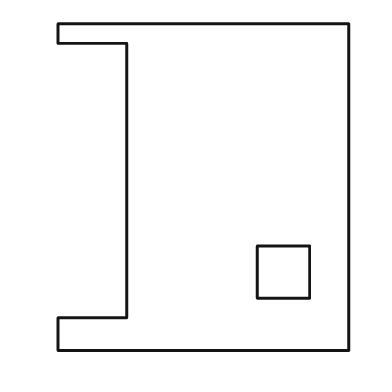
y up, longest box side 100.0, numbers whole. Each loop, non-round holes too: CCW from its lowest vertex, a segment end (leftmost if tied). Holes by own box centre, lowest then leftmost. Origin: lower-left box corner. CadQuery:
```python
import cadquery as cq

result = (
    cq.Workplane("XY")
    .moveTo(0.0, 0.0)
    .lineTo(89.0, 0.0)
    .lineTo(89.0, 100.0)
    .lineTo(0.0, 100.0)
    .lineTo(0.0, 94.0)
    .lineTo(21.0, 94.0)
    .lineTo(21.0, 10.0)
    .lineTo(0.0, 10.0)
    .close()
    .moveTo(61.0, 16.0)
    .lineTo(77.0, 16.0)
    .lineTo(77.0, 32.0)
    .lineTo(61.0, 32.0)
    .close()
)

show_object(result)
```